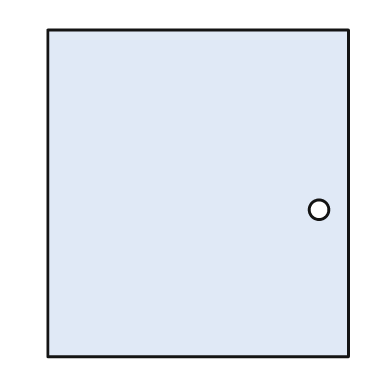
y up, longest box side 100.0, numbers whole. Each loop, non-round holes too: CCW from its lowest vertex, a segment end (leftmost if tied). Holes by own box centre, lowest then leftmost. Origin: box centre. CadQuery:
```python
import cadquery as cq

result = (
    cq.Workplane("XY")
    .moveTo(-46.0, -50.0)
    .lineTo(46.0, -50.0)
    .lineTo(46.0, 50.0)
    .lineTo(-46.0, 50.0)
    .close()
    .moveTo(37.0, -5.0)
    .circle(3.0)
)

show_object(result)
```